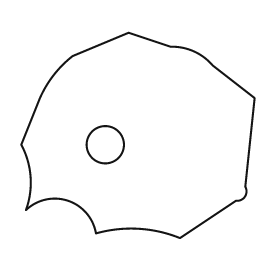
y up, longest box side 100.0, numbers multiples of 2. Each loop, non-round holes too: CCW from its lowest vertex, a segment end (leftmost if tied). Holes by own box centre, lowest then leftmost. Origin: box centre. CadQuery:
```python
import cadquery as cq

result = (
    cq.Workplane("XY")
    .moveTo(18.0, -44.0)
    .lineTo(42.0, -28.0)
    .threePointArc((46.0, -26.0), (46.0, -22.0))
    .lineTo(50.0, 16.0)
    .lineTo(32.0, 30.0)
    .threePointArc((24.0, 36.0), (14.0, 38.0))
    .lineTo(-4.0, 44.0)
    .lineTo(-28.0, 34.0)
    .threePointArc((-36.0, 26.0), (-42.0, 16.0))
    .lineTo(-50.0, -4.0)
    .threePointArc((-46.0, -18.0), (-48.0, -32.0))
    .threePointArc((-30.0, -28.0), (-18.0, -42.0))
    .threePointArc((0.0, -40.0), (18.0, -44.0))
    .close()
    .moveTo(-14.0, -4.0)
    .circle(8.0)
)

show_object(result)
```